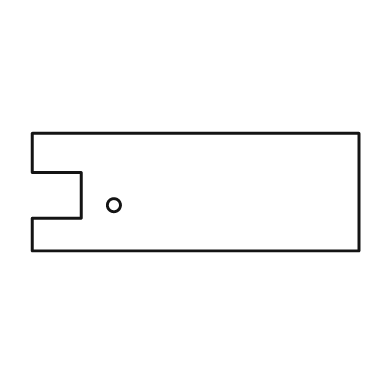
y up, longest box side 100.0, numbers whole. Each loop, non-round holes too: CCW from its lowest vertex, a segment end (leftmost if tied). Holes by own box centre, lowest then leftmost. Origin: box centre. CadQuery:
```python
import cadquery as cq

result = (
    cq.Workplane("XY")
    .moveTo(-50.0, -18.0)
    .lineTo(50.0, -18.0)
    .lineTo(50.0, 18.0)
    .lineTo(-50.0, 18.0)
    .lineTo(-50.0, 6.0)
    .lineTo(-35.0, 6.0)
    .lineTo(-35.0, -8.0)
    .lineTo(-50.0, -8.0)
    .close()
    .moveTo(-25.0, -4.0)
    .circle(2.0)
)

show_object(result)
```